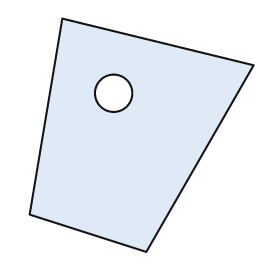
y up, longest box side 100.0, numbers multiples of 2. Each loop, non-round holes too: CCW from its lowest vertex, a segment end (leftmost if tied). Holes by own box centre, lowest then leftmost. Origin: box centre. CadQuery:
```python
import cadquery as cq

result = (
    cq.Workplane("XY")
    .moveTo(2.0, -50.0)
    .lineTo(48.0, 30.0)
    .lineTo(-34.0, 50.0)
    .lineTo(-48.0, -34.0)
    .close()
    .moveTo(-12.0, 18.0)
    .circle(8.0)
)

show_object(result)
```